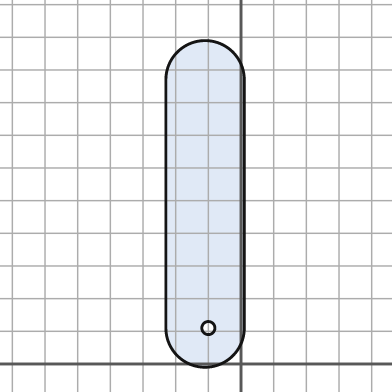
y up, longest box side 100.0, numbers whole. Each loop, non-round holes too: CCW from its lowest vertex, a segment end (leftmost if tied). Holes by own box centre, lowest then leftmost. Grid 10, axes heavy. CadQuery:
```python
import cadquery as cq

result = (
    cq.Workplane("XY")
    .moveTo(-23.0, 11.0)
    .threePointArc((-11.0, -1.0), (1.0, 11.0))
    .lineTo(1.0, 87.0)
    .threePointArc((-11.0, 99.0), (-23.0, 87.0))
    .close()
    .moveTo(-10.0, 11.0)
    .circle(2.0)
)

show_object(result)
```